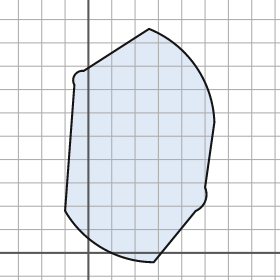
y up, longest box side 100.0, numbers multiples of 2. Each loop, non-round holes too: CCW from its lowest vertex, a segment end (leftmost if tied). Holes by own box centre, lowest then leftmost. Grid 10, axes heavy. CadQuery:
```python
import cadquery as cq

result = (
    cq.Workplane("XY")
    .moveTo(28.0, -4.0)
    .lineTo(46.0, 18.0)
    .threePointArc((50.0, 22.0), (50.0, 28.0))
    .lineTo(54.0, 56.0)
    .threePointArc((46.0, 80.0), (26.0, 96.0))
    .lineTo(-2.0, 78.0)
    .threePointArc((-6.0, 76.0), (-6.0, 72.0))
    .lineTo(-10.0, 18.0)
    .threePointArc((6.0, 2.0), (28.0, -4.0))
    .close()
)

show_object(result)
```